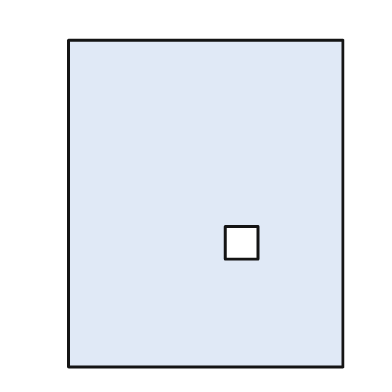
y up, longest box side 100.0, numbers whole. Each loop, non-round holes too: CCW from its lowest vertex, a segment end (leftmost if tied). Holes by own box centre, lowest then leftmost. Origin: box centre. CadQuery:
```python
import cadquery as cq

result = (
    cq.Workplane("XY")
    .moveTo(-42.0, -50.0)
    .lineTo(42.0, -50.0)
    .lineTo(42.0, 50.0)
    .lineTo(-42.0, 50.0)
    .close()
    .moveTo(6.0, -17.0)
    .lineTo(16.0, -17.0)
    .lineTo(16.0, -7.0)
    .lineTo(6.0, -7.0)
    .close()
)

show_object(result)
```